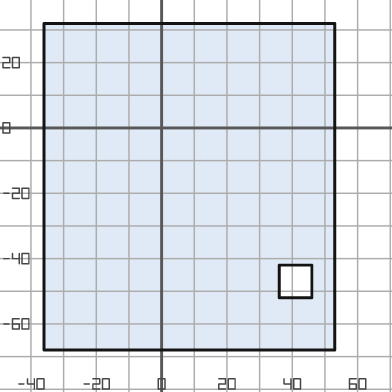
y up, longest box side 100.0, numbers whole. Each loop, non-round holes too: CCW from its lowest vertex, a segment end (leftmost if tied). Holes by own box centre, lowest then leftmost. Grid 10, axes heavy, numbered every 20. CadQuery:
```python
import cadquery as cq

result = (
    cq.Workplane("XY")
    .moveTo(-36.0, -68.0)
    .lineTo(53.0, -68.0)
    .lineTo(53.0, 32.0)
    .lineTo(-36.0, 32.0)
    .close()
    .moveTo(36.0, -52.0)
    .lineTo(46.0, -52.0)
    .lineTo(46.0, -42.0)
    .lineTo(36.0, -42.0)
    .close()
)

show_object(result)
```